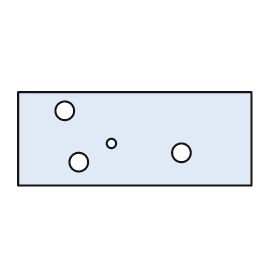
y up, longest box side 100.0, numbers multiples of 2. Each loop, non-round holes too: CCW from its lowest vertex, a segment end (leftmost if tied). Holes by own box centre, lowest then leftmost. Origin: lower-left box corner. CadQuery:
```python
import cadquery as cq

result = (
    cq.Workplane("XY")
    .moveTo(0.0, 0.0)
    .lineTo(100.0, 0.0)
    .lineTo(100.0, 40.0)
    .lineTo(0.0, 40.0)
    .close()
    .moveTo(26.0, 10.0)
    .circle(4.0)
    .moveTo(70.0, 14.0)
    .circle(4.0)
    .moveTo(40.0, 18.0)
    .circle(2.0)
    .moveTo(20.0, 32.0)
    .circle(4.0)
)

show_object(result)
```